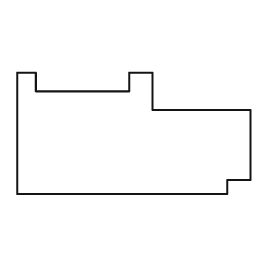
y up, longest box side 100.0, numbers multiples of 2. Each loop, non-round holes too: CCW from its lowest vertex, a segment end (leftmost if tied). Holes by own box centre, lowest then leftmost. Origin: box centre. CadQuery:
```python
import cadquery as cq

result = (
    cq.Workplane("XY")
    .moveTo(-50.0, -26.0)
    .lineTo(40.0, -26.0)
    .lineTo(40.0, -20.0)
    .lineTo(50.0, -20.0)
    .lineTo(50.0, 10.0)
    .lineTo(8.0, 10.0)
    .lineTo(8.0, 26.0)
    .lineTo(-2.0, 26.0)
    .lineTo(-2.0, 18.0)
    .lineTo(-42.0, 18.0)
    .lineTo(-42.0, 26.0)
    .lineTo(-50.0, 26.0)
    .close()
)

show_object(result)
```